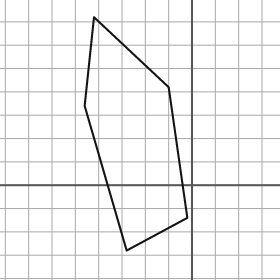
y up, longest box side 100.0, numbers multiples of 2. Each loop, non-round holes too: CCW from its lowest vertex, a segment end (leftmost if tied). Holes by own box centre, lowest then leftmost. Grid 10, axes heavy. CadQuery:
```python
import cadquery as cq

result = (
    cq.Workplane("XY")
    .moveTo(-28.0, -28.0)
    .lineTo(-2.0, -14.0)
    .lineTo(-10.0, 42.0)
    .lineTo(-42.0, 72.0)
    .lineTo(-46.0, 34.0)
    .close()
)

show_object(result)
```